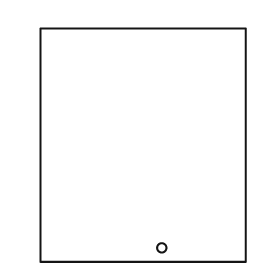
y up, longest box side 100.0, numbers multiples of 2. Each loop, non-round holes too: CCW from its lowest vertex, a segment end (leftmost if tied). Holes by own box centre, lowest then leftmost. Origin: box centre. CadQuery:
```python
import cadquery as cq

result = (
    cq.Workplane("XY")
    .moveTo(-44.0, -50.0)
    .lineTo(44.0, -50.0)
    .lineTo(44.0, 50.0)
    .lineTo(-44.0, 50.0)
    .close()
    .moveTo(8.0, -44.0)
    .circle(2.0)
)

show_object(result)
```